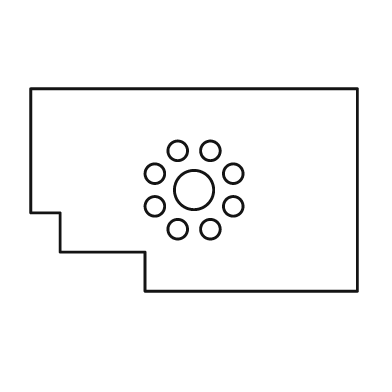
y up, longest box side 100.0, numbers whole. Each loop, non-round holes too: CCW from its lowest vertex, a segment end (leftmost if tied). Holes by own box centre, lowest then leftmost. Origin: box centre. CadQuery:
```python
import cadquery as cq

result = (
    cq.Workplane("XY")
    .moveTo(-15.0, -31.0)
    .lineTo(50.0, -31.0)
    .lineTo(50.0, 31.0)
    .lineTo(-50.0, 31.0)
    .lineTo(-50.0, -7.0)
    .lineTo(-41.0, -7.0)
    .lineTo(-41.0, -19.0)
    .lineTo(-15.0, -19.0)
    .close()
    .moveTo(-5.0, -12.0)
    .circle(3.0)
    .moveTo(5.0, -12.0)
    .circle(3.0)
    .moveTo(-12.0, -5.0)
    .circle(3.0)
    .moveTo(12.0, -5.0)
    .circle(3.0)
    .moveTo(0.0, 0.0)
    .circle(6.0)
    .moveTo(-12.0, 5.0)
    .circle(3.0)
    .moveTo(12.0, 5.0)
    .circle(3.0)
    .moveTo(-5.0, 12.0)
    .circle(3.0)
    .moveTo(5.0, 12.0)
    .circle(3.0)
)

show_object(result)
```